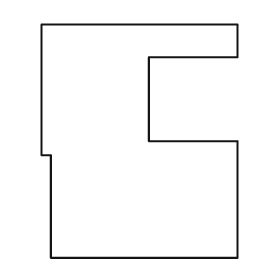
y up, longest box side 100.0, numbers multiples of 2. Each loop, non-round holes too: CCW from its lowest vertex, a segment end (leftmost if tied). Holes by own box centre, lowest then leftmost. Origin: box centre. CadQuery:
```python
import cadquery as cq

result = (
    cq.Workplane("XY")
    .moveTo(-38.0, -50.0)
    .lineTo(42.0, -50.0)
    .lineTo(42.0, 0.0)
    .lineTo(4.0, 0.0)
    .lineTo(4.0, 36.0)
    .lineTo(42.0, 36.0)
    .lineTo(42.0, 50.0)
    .lineTo(-42.0, 50.0)
    .lineTo(-42.0, -6.0)
    .lineTo(-38.0, -6.0)
    .close()
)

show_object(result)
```